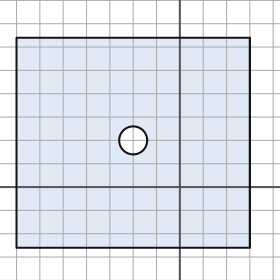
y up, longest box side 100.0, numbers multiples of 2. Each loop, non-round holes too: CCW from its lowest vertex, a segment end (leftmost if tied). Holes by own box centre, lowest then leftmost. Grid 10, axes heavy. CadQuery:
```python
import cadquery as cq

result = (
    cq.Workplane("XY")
    .moveTo(-70.0, -26.0)
    .lineTo(30.0, -26.0)
    .lineTo(30.0, 64.0)
    .lineTo(-70.0, 64.0)
    .close()
    .moveTo(-20.0, 20.0)
    .circle(6.0)
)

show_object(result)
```